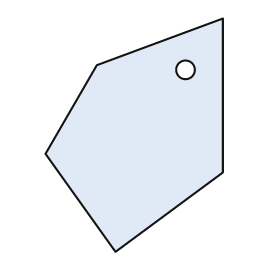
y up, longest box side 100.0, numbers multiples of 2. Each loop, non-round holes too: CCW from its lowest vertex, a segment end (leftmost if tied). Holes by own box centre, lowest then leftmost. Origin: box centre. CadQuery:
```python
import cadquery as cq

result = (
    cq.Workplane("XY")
    .moveTo(-8.0, -50.0)
    .lineTo(38.0, -16.0)
    .lineTo(38.0, 50.0)
    .lineTo(-16.0, 30.0)
    .lineTo(-38.0, -8.0)
    .close()
    .moveTo(22.0, 28.0)
    .circle(4.0)
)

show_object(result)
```